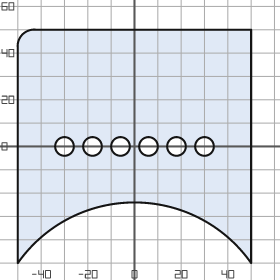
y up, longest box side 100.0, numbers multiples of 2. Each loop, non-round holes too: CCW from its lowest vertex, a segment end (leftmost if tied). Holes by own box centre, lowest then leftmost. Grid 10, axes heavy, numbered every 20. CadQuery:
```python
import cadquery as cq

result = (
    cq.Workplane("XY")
    .moveTo(-50.0, -50.0)
    .threePointArc((0.0, -24.0), (50.0, -50.0))
    .lineTo(50.0, 50.0)
    .lineTo(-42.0, 50.0)
    .threePointArc((-48.0, 48.0), (-50.0, 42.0))
    .close()
    .moveTo(-30.0, 0.0)
    .circle(4.0)
    .moveTo(-18.0, 0.0)
    .circle(4.0)
    .moveTo(-6.0, 0.0)
    .circle(4.0)
    .moveTo(6.0, 0.0)
    .circle(4.0)
    .moveTo(18.0, 0.0)
    .circle(4.0)
    .moveTo(30.0, 0.0)
    .circle(4.0)
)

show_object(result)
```